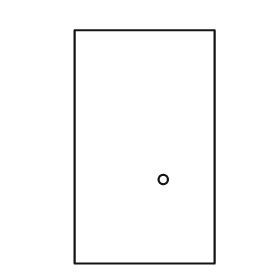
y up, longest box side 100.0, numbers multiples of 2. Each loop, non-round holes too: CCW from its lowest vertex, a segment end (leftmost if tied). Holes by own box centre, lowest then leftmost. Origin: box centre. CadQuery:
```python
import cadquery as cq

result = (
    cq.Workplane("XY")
    .moveTo(-30.0, -50.0)
    .lineTo(30.0, -50.0)
    .lineTo(30.0, 50.0)
    .lineTo(-30.0, 50.0)
    .close()
    .moveTo(8.0, -14.0)
    .circle(2.0)
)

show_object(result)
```